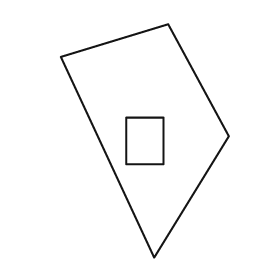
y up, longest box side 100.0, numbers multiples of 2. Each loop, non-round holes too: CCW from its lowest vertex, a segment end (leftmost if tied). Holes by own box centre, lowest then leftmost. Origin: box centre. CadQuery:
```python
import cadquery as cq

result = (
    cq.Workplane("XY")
    .moveTo(4.0, -50.0)
    .lineTo(36.0, 2.0)
    .lineTo(10.0, 50.0)
    .lineTo(-36.0, 36.0)
    .close()
    .moveTo(-8.0, -10.0)
    .lineTo(8.0, -10.0)
    .lineTo(8.0, 10.0)
    .lineTo(-8.0, 10.0)
    .close()
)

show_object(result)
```